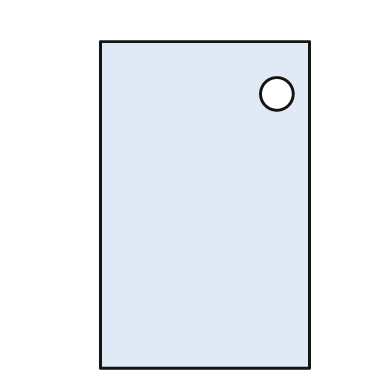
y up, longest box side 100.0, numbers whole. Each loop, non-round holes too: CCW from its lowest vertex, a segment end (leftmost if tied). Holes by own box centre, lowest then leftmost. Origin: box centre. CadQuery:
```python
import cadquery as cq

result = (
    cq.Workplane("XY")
    .moveTo(-32.0, -50.0)
    .lineTo(32.0, -50.0)
    .lineTo(32.0, 50.0)
    .lineTo(-32.0, 50.0)
    .close()
    .moveTo(22.0, 34.0)
    .circle(5.0)
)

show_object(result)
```